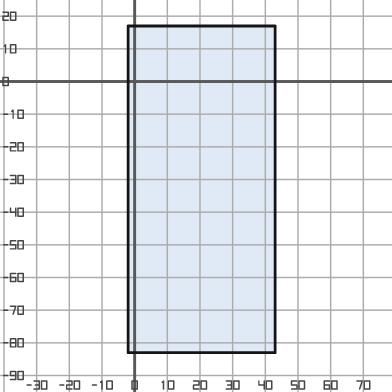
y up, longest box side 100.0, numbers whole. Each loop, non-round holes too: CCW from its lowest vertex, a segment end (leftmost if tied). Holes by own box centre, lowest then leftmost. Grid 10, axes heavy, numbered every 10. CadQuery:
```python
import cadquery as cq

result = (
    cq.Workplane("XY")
    .moveTo(-2.0, -83.0)
    .lineTo(43.0, -83.0)
    .lineTo(43.0, 17.0)
    .lineTo(-2.0, 17.0)
    .close()
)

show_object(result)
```